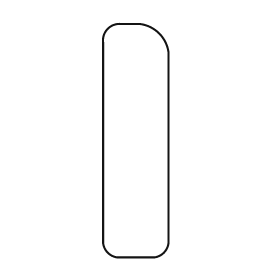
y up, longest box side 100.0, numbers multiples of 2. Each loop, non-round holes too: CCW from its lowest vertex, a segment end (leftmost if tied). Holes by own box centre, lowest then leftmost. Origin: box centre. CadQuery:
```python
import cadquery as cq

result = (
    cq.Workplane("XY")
    .moveTo(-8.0, -50.0)
    .lineTo(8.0, -50.0)
    .threePointArc((12.0, -48.0), (14.0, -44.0))
    .lineTo(14.0, 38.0)
    .threePointArc((10.0, 46.0), (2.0, 50.0))
    .lineTo(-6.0, 50.0)
    .threePointArc((-12.0, 48.0), (-14.0, 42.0))
    .lineTo(-14.0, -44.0)
    .threePointArc((-12.0, -48.0), (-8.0, -50.0))
    .close()
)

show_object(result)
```